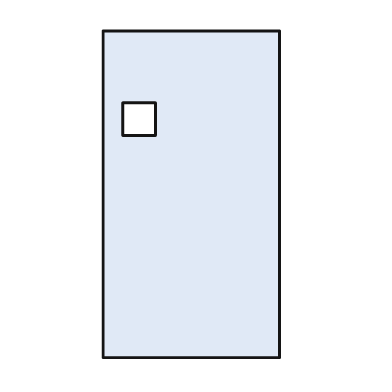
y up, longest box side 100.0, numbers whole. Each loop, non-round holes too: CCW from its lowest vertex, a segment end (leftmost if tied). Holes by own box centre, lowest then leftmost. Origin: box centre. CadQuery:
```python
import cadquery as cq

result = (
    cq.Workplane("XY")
    .moveTo(-27.0, -50.0)
    .lineTo(27.0, -50.0)
    .lineTo(27.0, 50.0)
    .lineTo(-27.0, 50.0)
    .close()
    .moveTo(-21.0, 18.0)
    .lineTo(-11.0, 18.0)
    .lineTo(-11.0, 28.0)
    .lineTo(-21.0, 28.0)
    .close()
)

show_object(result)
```